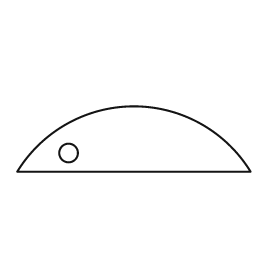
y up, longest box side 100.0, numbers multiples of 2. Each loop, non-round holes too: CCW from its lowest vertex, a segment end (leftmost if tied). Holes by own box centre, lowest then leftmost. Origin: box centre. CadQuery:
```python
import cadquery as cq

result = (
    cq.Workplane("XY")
    .moveTo(-50.0, -14.0)
    .lineTo(50.0, -14.0)
    .threePointArc((0.0, 14.0), (-50.0, -14.0))
    .close()
    .moveTo(-28.0, -6.0)
    .circle(4.0)
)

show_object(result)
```